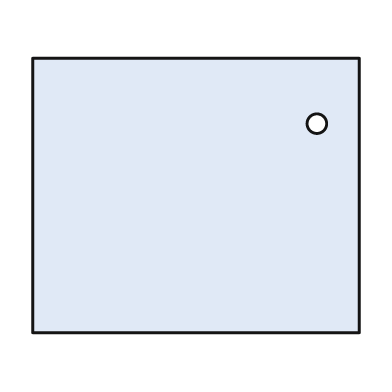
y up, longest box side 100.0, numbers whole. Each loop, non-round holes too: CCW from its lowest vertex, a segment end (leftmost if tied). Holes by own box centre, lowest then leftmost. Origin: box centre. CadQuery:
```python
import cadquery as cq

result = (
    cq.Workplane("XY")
    .moveTo(-50.0, -42.0)
    .lineTo(50.0, -42.0)
    .lineTo(50.0, 42.0)
    .lineTo(-50.0, 42.0)
    .close()
    .moveTo(37.0, 22.0)
    .circle(3.0)
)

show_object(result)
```